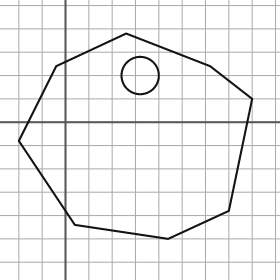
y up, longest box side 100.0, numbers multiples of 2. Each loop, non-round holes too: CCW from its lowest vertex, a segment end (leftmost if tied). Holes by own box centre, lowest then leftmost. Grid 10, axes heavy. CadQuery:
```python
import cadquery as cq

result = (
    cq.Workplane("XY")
    .moveTo(44.0, -50.0)
    .lineTo(70.0, -38.0)
    .lineTo(80.0, 10.0)
    .lineTo(62.0, 24.0)
    .lineTo(26.0, 38.0)
    .lineTo(-4.0, 24.0)
    .lineTo(-20.0, -8.0)
    .lineTo(4.0, -44.0)
    .close()
    .moveTo(32.0, 20.0)
    .circle(8.0)
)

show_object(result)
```